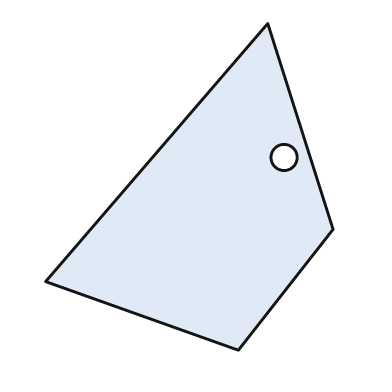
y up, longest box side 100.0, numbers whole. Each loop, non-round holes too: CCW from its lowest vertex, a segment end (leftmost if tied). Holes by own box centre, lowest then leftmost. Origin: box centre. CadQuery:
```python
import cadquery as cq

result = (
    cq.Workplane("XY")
    .moveTo(15.0, -50.0)
    .lineTo(44.0, -13.0)
    .lineTo(24.0, 50.0)
    .lineTo(-44.0, -29.0)
    .close()
    .moveTo(29.0, 9.0)
    .circle(4.0)
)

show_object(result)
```